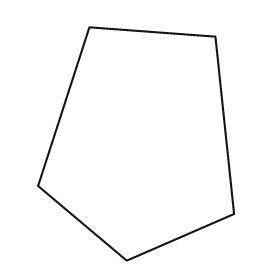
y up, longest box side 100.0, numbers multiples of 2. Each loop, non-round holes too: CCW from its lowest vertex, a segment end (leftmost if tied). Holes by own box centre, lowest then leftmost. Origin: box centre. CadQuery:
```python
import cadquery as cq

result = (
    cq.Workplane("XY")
    .moveTo(-4.0, -50.0)
    .lineTo(42.0, -30.0)
    .lineTo(34.0, 46.0)
    .lineTo(-20.0, 50.0)
    .lineTo(-42.0, -18.0)
    .close()
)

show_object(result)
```